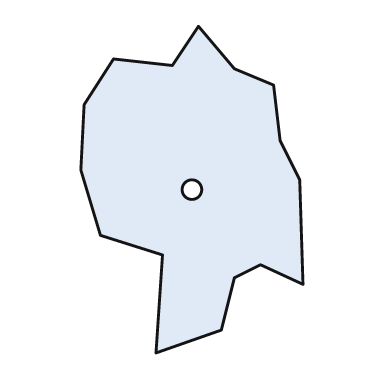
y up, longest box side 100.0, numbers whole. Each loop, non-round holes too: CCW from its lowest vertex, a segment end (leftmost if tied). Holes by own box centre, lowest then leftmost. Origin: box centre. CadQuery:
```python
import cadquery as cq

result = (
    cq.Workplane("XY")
    .moveTo(-11.0, -50.0)
    .lineTo(9.0, -43.0)
    .lineTo(13.0, -27.0)
    .lineTo(21.0, -23.0)
    .lineTo(34.0, -29.0)
    .lineTo(33.0, 3.0)
    .lineTo(27.0, 15.0)
    .lineTo(25.0, 32.0)
    .lineTo(13.0, 37.0)
    .lineTo(2.0, 50.0)
    .lineTo(-6.0, 38.0)
    .lineTo(-24.0, 40.0)
    .lineTo(-33.0, 26.0)
    .lineTo(-34.0, 6.0)
    .lineTo(-28.0, -14.0)
    .lineTo(-9.0, -20.0)
    .close()
    .moveTo(0.0, 0.0)
    .circle(3.0)
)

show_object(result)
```